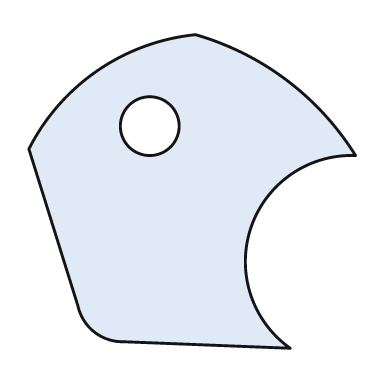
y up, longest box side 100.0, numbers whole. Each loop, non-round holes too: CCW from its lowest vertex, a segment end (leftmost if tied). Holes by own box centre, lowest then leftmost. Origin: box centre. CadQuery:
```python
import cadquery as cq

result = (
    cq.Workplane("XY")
    .moveTo(30.0, -48.0)
    .threePointArc((18.0, -11.0), (50.0, 11.0))
    .threePointArc((29.0, 34.0), (1.0, 48.0))
    .threePointArc((-29.0, 37.0), (-50.0, 13.0))
    .lineTo(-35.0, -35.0)
    .threePointArc((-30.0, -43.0), (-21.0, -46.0))
    .close()
    .moveTo(-13.0, 20.0)
    .circle(9.0)
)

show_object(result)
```